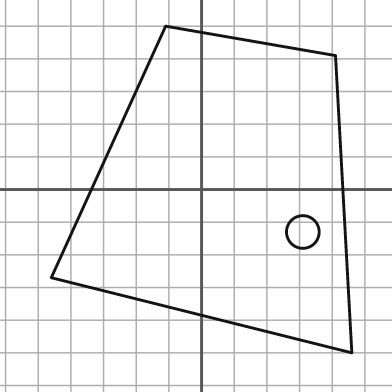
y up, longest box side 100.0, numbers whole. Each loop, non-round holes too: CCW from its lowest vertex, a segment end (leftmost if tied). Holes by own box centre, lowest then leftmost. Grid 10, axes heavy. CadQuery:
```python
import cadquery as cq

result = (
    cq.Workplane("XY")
    .moveTo(46.0, -50.0)
    .lineTo(41.0, 41.0)
    .lineTo(-11.0, 50.0)
    .lineTo(-46.0, -27.0)
    .close()
    .moveTo(31.0, -13.0)
    .circle(5.0)
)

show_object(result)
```